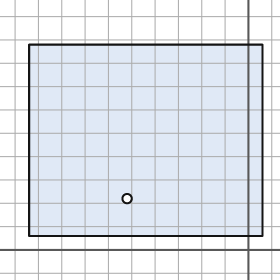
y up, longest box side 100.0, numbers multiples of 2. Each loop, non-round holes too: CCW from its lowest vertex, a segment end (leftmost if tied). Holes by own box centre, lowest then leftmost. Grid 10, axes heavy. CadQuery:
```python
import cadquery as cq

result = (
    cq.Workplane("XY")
    .moveTo(-94.0, 6.0)
    .lineTo(6.0, 6.0)
    .lineTo(6.0, 88.0)
    .lineTo(-94.0, 88.0)
    .close()
    .moveTo(-52.0, 22.0)
    .circle(2.0)
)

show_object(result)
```